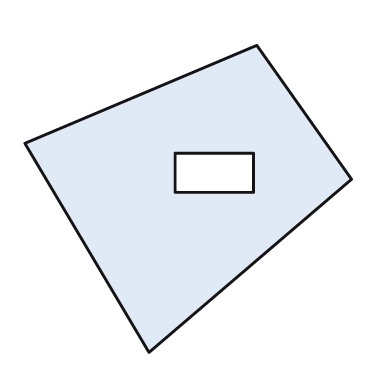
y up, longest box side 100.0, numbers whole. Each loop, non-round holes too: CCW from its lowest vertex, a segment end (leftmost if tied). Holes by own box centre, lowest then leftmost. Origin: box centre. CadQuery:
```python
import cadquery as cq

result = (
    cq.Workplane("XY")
    .moveTo(-12.0, -47.0)
    .lineTo(50.0, 6.0)
    .lineTo(21.0, 47.0)
    .lineTo(-50.0, 17.0)
    .close()
    .moveTo(-4.0, 2.0)
    .lineTo(20.0, 2.0)
    .lineTo(20.0, 14.0)
    .lineTo(-4.0, 14.0)
    .close()
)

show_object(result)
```